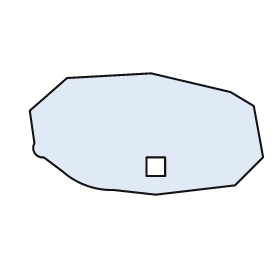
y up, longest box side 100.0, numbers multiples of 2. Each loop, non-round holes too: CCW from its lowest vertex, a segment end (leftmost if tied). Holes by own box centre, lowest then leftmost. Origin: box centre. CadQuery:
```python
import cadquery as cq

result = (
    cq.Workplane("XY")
    .moveTo(4.0, -26.0)
    .lineTo(38.0, -22.0)
    .lineTo(50.0, -10.0)
    .lineTo(46.0, 12.0)
    .lineTo(36.0, 18.0)
    .lineTo(2.0, 26.0)
    .lineTo(-34.0, 24.0)
    .lineTo(-50.0, 10.0)
    .lineTo(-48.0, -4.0)
    .threePointArc((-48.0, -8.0), (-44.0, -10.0))
    .lineTo(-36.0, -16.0)
    .threePointArc((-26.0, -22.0), (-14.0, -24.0))
    .close()
    .moveTo(0.0, -18.0)
    .lineTo(8.0, -18.0)
    .lineTo(8.0, -10.0)
    .lineTo(0.0, -10.0)
    .close()
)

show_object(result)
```